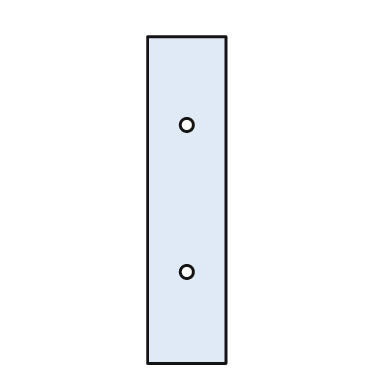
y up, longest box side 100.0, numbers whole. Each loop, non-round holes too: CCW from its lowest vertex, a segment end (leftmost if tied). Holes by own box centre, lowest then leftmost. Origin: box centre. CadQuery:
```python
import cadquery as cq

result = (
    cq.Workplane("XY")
    .moveTo(-12.0, -50.0)
    .lineTo(12.0, -50.0)
    .lineTo(12.0, 50.0)
    .lineTo(-12.0, 50.0)
    .close()
    .moveTo(0.0, -22.0)
    .circle(2.0)
    .moveTo(0.0, 23.0)
    .circle(2.0)
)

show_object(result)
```